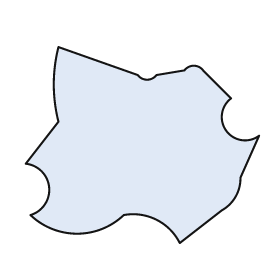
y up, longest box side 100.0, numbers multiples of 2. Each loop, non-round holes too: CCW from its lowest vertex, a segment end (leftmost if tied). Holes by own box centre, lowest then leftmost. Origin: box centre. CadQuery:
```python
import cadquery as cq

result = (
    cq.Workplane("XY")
    .moveTo(16.0, -42.0)
    .lineTo(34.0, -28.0)
    .threePointArc((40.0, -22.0), (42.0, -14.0))
    .lineTo(50.0, 4.0)
    .threePointArc((36.0, 6.0), (38.0, 20.0))
    .lineTo(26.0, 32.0)
    .threePointArc((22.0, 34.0), (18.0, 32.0))
    .lineTo(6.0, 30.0)
    .threePointArc((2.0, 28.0), (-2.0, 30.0))
    .lineTo(-36.0, 42.0)
    .threePointArc((-38.0, 26.0), (-36.0, 10.0))
    .lineTo(-50.0, -8.0)
    .threePointArc((-40.0, -18.0), (-48.0, -30.0))
    .threePointArc((-28.0, -38.0), (-8.0, -30.0))
    .threePointArc((6.0, -32.0), (16.0, -42.0))
    .close()
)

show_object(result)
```